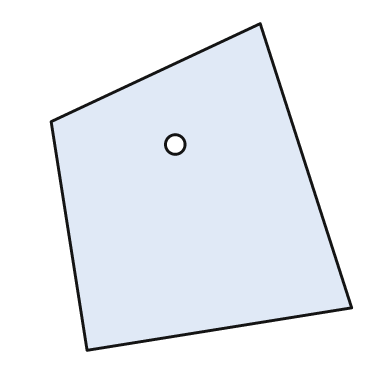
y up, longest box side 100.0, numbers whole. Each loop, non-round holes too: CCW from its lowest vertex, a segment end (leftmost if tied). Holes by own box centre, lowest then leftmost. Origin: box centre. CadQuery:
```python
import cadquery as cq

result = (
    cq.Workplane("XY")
    .moveTo(-35.0, -50.0)
    .lineTo(46.0, -37.0)
    .lineTo(18.0, 50.0)
    .lineTo(-46.0, 20.0)
    .close()
    .moveTo(-8.0, 13.0)
    .circle(3.0)
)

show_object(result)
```